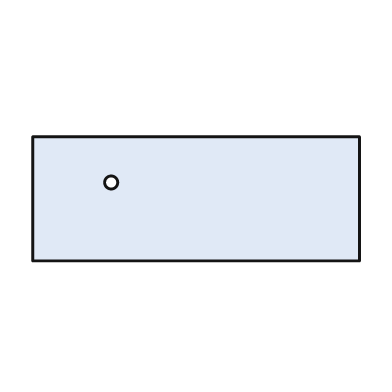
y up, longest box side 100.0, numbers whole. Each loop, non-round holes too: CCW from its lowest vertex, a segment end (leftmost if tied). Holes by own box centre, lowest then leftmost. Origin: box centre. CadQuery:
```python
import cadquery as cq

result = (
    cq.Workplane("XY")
    .moveTo(-50.0, -19.0)
    .lineTo(50.0, -19.0)
    .lineTo(50.0, 19.0)
    .lineTo(-50.0, 19.0)
    .close()
    .moveTo(-26.0, 5.0)
    .circle(2.0)
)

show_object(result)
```